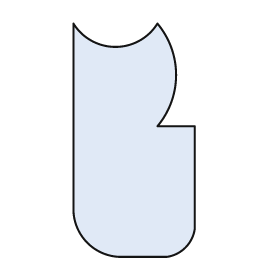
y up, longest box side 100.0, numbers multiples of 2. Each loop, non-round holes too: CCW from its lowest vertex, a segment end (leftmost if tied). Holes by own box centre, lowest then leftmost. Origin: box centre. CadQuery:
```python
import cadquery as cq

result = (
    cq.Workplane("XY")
    .moveTo(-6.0, -50.0)
    .lineTo(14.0, -50.0)
    .threePointArc((22.0, -46.0), (26.0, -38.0))
    .lineTo(26.0, 6.0)
    .lineTo(10.0, 6.0)
    .threePointArc((18.0, 28.0), (10.0, 50.0))
    .threePointArc((-8.0, 40.0), (-26.0, 50.0))
    .lineTo(-26.0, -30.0)
    .threePointArc((-20.0, -44.0), (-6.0, -50.0))
    .close()
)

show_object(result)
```